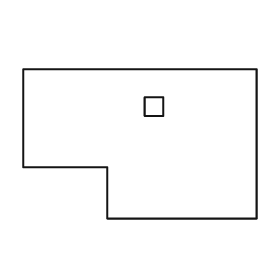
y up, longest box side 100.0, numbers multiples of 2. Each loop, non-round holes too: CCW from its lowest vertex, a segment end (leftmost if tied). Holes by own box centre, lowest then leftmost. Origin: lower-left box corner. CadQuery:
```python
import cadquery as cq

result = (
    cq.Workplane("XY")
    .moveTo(36.0, 0.0)
    .lineTo(100.0, 0.0)
    .lineTo(100.0, 64.0)
    .lineTo(0.0, 64.0)
    .lineTo(0.0, 22.0)
    .lineTo(36.0, 22.0)
    .close()
    .moveTo(52.0, 44.0)
    .lineTo(60.0, 44.0)
    .lineTo(60.0, 52.0)
    .lineTo(52.0, 52.0)
    .close()
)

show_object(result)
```